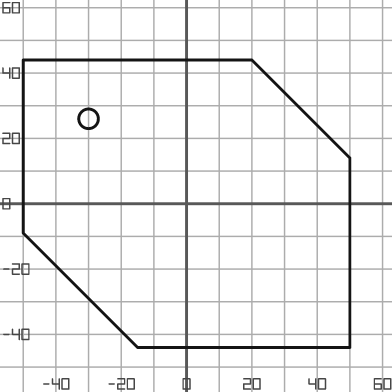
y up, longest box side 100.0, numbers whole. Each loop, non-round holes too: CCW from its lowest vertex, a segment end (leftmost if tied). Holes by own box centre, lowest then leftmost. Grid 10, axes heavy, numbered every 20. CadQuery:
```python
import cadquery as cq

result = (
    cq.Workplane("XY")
    .moveTo(-15.0, -44.0)
    .lineTo(50.0, -44.0)
    .lineTo(50.0, 14.0)
    .lineTo(20.0, 44.0)
    .lineTo(-50.0, 44.0)
    .lineTo(-50.0, -9.0)
    .close()
    .moveTo(-30.0, 26.0)
    .circle(3.0)
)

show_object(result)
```